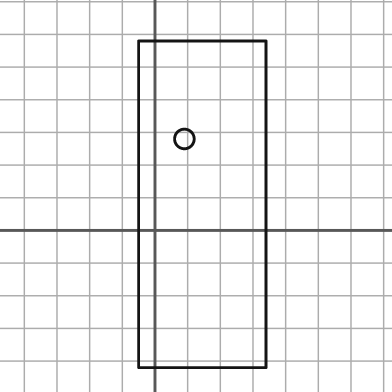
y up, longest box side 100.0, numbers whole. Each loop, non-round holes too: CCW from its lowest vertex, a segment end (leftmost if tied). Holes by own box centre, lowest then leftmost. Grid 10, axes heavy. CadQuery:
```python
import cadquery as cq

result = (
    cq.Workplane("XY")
    .moveTo(-5.0, -42.0)
    .lineTo(34.0, -42.0)
    .lineTo(34.0, 58.0)
    .lineTo(-5.0, 58.0)
    .close()
    .moveTo(9.0, 28.0)
    .circle(3.0)
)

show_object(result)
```